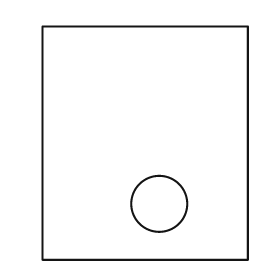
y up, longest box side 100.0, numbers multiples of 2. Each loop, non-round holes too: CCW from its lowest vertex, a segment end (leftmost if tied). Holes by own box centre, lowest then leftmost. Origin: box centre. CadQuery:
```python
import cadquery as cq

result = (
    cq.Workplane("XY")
    .moveTo(-44.0, -50.0)
    .lineTo(44.0, -50.0)
    .lineTo(44.0, 50.0)
    .lineTo(-44.0, 50.0)
    .close()
    .moveTo(6.0, -26.0)
    .circle(12.0)
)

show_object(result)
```